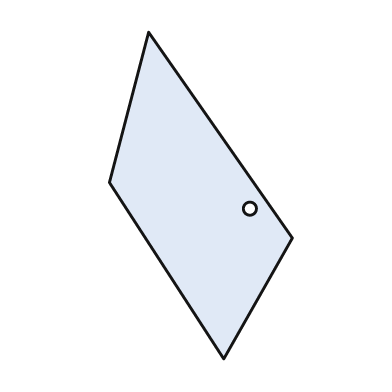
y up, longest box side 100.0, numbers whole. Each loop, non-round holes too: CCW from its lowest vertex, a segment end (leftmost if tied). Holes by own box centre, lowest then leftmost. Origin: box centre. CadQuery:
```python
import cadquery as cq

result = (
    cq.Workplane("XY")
    .moveTo(7.0, -50.0)
    .lineTo(28.0, -13.0)
    .lineTo(-16.0, 50.0)
    .lineTo(-28.0, 4.0)
    .close()
    .moveTo(15.0, -4.0)
    .circle(2.0)
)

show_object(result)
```